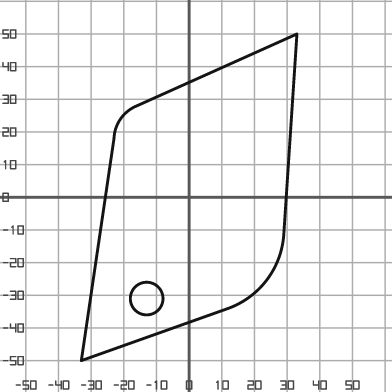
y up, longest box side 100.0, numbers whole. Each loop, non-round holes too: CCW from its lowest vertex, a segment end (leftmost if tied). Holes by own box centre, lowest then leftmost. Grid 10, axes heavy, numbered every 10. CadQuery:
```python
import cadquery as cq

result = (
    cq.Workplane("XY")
    .moveTo(-33.0, -50.0)
    .lineTo(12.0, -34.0)
    .threePointArc((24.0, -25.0), (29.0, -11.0))
    .lineTo(33.0, 50.0)
    .lineTo(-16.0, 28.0)
    .threePointArc((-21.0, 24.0), (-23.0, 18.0))
    .close()
    .moveTo(-13.0, -31.0)
    .circle(5.0)
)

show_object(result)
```